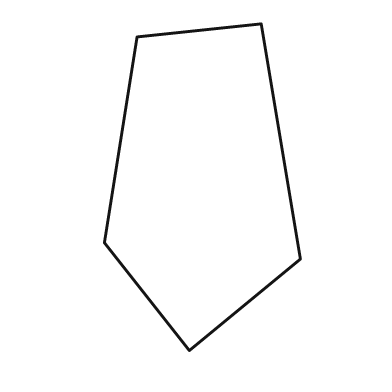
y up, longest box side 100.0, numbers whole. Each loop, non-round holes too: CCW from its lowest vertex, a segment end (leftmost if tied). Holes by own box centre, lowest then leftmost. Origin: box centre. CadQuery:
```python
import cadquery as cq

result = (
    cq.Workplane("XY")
    .moveTo(-4.0, -50.0)
    .lineTo(30.0, -22.0)
    .lineTo(18.0, 50.0)
    .lineTo(-20.0, 46.0)
    .lineTo(-30.0, -17.0)
    .close()
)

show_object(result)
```